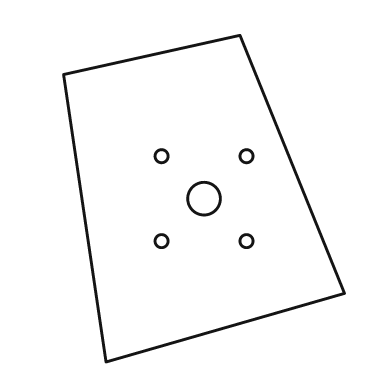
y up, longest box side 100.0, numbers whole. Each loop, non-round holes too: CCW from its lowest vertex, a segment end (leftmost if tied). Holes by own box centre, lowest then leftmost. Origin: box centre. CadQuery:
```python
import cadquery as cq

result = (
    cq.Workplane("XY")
    .moveTo(-30.0, -50.0)
    .lineTo(43.0, -29.0)
    .lineTo(11.0, 50.0)
    .lineTo(-43.0, 38.0)
    .close()
    .moveTo(-13.0, -13.0)
    .circle(2.0)
    .moveTo(13.0, -13.0)
    .circle(2.0)
    .moveTo(0.0, 0.0)
    .circle(5.0)
    .moveTo(-13.0, 13.0)
    .circle(2.0)
    .moveTo(13.0, 13.0)
    .circle(2.0)
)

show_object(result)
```